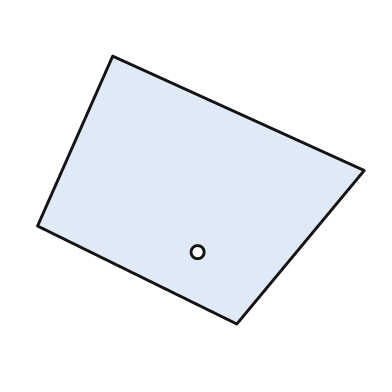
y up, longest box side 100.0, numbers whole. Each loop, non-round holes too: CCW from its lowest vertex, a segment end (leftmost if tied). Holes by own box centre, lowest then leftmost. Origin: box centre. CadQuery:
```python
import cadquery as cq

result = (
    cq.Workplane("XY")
    .moveTo(11.0, -41.0)
    .lineTo(50.0, 6.0)
    .lineTo(-27.0, 41.0)
    .lineTo(-50.0, -11.0)
    .close()
    .moveTo(-1.0, -19.0)
    .circle(2.0)
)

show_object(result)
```